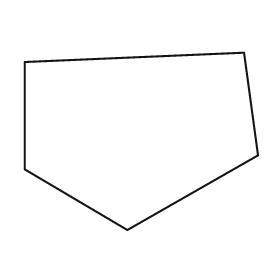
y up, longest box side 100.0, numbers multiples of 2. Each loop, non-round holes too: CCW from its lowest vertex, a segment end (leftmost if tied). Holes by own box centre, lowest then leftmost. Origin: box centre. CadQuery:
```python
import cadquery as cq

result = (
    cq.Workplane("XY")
    .moveTo(-6.0, -38.0)
    .lineTo(50.0, -6.0)
    .lineTo(44.0, 38.0)
    .lineTo(-50.0, 34.0)
    .lineTo(-50.0, -12.0)
    .close()
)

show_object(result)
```